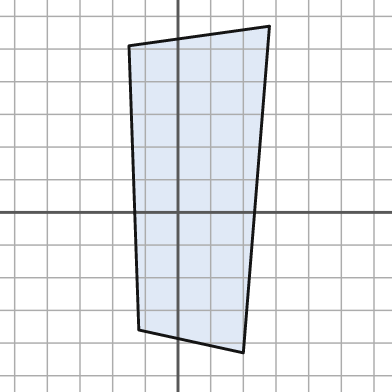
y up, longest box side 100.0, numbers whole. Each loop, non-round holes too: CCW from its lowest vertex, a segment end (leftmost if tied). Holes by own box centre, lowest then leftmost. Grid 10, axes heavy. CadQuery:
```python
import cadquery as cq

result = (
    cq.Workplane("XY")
    .moveTo(20.0, -43.0)
    .lineTo(28.0, 57.0)
    .lineTo(-15.0, 51.0)
    .lineTo(-12.0, -36.0)
    .close()
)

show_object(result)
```